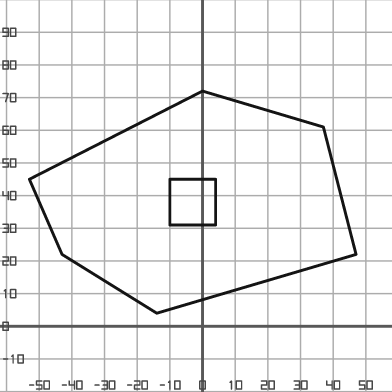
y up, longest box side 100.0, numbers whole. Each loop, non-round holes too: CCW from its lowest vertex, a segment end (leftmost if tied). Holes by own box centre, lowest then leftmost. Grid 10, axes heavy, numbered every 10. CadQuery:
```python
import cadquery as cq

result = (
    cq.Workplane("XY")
    .moveTo(-14.0, 4.0)
    .lineTo(47.0, 22.0)
    .lineTo(37.0, 61.0)
    .lineTo(0.0, 72.0)
    .lineTo(-53.0, 45.0)
    .lineTo(-43.0, 22.0)
    .close()
    .moveTo(-10.0, 31.0)
    .lineTo(4.0, 31.0)
    .lineTo(4.0, 45.0)
    .lineTo(-10.0, 45.0)
    .close()
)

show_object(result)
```